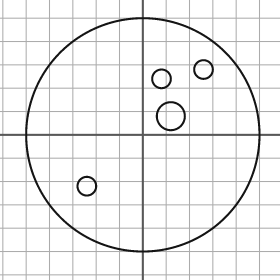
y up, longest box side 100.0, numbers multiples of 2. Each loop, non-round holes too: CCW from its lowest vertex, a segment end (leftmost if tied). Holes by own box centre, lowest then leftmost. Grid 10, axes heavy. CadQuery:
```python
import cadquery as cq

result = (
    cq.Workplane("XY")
    .moveTo(0.0, 0.0)
    .circle(50.0)
    .moveTo(-24.0, -22.0)
    .circle(4.0)
    .moveTo(12.0, 8.0)
    .circle(6.0)
    .moveTo(8.0, 24.0)
    .circle(4.0)
    .moveTo(26.0, 28.0)
    .circle(4.0)
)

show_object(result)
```